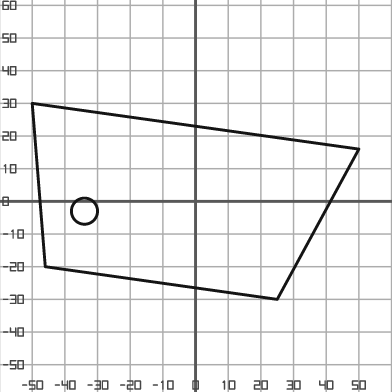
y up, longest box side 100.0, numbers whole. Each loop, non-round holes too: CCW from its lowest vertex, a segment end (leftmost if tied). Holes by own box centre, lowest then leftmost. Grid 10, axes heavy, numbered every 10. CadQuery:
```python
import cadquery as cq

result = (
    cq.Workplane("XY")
    .moveTo(25.0, -30.0)
    .lineTo(50.0, 16.0)
    .lineTo(-50.0, 30.0)
    .lineTo(-46.0, -20.0)
    .close()
    .moveTo(-34.0, -3.0)
    .circle(4.0)
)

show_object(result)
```